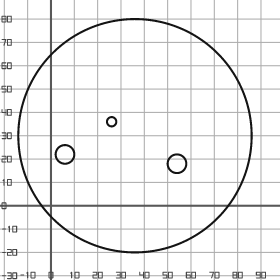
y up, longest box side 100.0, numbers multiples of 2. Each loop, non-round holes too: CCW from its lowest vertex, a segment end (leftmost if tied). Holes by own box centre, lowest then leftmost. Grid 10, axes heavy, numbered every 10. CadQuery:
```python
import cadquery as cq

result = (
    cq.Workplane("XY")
    .moveTo(36.0, 30.0)
    .circle(50.0)
    .moveTo(54.0, 18.0)
    .circle(4.0)
    .moveTo(6.0, 22.0)
    .circle(4.0)
    .moveTo(26.0, 36.0)
    .circle(2.0)
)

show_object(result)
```